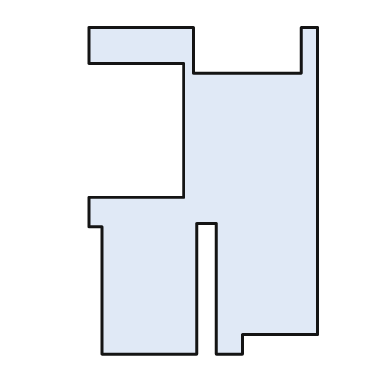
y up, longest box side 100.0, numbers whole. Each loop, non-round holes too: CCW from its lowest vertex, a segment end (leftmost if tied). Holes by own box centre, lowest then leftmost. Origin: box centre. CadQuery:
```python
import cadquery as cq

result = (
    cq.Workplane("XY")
    .moveTo(-31.0, -50.0)
    .lineTo(-2.0, -50.0)
    .lineTo(-2.0, -10.0)
    .lineTo(4.0, -10.0)
    .lineTo(4.0, -50.0)
    .lineTo(12.0, -50.0)
    .lineTo(12.0, -44.0)
    .lineTo(35.0, -44.0)
    .lineTo(35.0, 50.0)
    .lineTo(30.0, 50.0)
    .lineTo(30.0, 36.0)
    .lineTo(-3.0, 36.0)
    .lineTo(-3.0, 50.0)
    .lineTo(-35.0, 50.0)
    .lineTo(-35.0, 39.0)
    .lineTo(-6.0, 39.0)
    .lineTo(-6.0, -2.0)
    .lineTo(-35.0, -2.0)
    .lineTo(-35.0, -11.0)
    .lineTo(-31.0, -11.0)
    .close()
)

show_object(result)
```